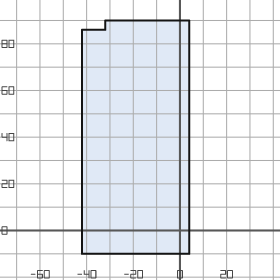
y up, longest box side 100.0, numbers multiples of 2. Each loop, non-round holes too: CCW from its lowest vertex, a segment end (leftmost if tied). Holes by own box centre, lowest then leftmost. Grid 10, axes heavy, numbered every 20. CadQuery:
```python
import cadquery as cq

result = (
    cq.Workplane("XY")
    .moveTo(-42.0, -10.0)
    .lineTo(4.0, -10.0)
    .lineTo(4.0, 90.0)
    .lineTo(-32.0, 90.0)
    .lineTo(-32.0, 86.0)
    .lineTo(-42.0, 86.0)
    .close()
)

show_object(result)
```